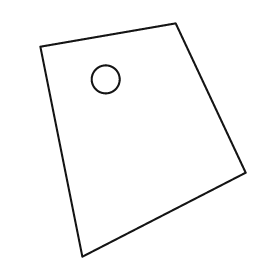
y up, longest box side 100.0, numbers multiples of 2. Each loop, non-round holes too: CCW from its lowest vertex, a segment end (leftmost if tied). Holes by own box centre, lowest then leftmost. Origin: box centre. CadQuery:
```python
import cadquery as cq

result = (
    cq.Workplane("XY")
    .moveTo(-26.0, -50.0)
    .lineTo(44.0, -14.0)
    .lineTo(14.0, 50.0)
    .lineTo(-44.0, 40.0)
    .close()
    .moveTo(-16.0, 26.0)
    .circle(6.0)
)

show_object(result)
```